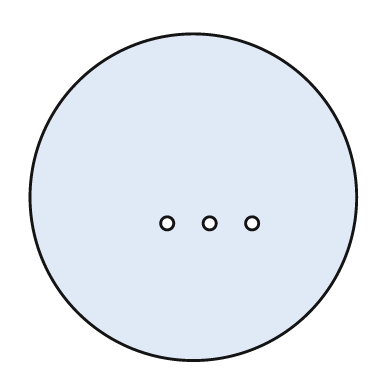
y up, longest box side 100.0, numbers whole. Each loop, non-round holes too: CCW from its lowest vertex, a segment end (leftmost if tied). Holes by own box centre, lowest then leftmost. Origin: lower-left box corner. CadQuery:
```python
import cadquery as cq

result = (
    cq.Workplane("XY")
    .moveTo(50.0, 50.0)
    .circle(50.0)
    .moveTo(42.0, 42.0)
    .circle(2.0)
    .moveTo(55.0, 42.0)
    .circle(2.0)
    .moveTo(68.0, 42.0)
    .circle(2.0)
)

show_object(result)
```